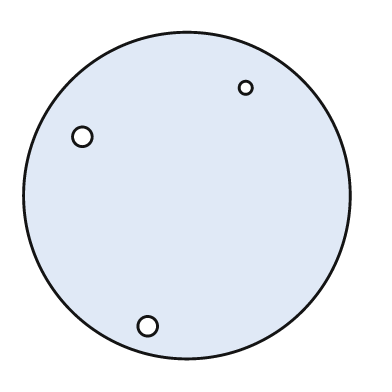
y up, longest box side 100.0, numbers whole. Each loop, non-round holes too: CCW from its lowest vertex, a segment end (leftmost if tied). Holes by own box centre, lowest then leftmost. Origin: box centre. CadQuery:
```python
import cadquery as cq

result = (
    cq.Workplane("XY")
    .moveTo(0.0, 0.0)
    .circle(50.0)
    .moveTo(-12.0, -40.0)
    .circle(3.0)
    .moveTo(-32.0, 18.0)
    .circle(3.0)
    .moveTo(18.0, 33.0)
    .circle(2.0)
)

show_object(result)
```